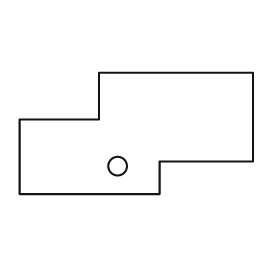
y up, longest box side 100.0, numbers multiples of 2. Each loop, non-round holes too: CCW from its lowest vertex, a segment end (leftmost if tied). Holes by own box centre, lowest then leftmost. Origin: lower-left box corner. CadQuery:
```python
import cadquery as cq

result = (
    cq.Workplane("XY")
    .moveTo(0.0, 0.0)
    .lineTo(60.0, 0.0)
    .lineTo(60.0, 14.0)
    .lineTo(100.0, 14.0)
    .lineTo(100.0, 52.0)
    .lineTo(34.0, 52.0)
    .lineTo(34.0, 32.0)
    .lineTo(0.0, 32.0)
    .close()
    .moveTo(42.0, 12.0)
    .circle(4.0)
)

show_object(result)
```